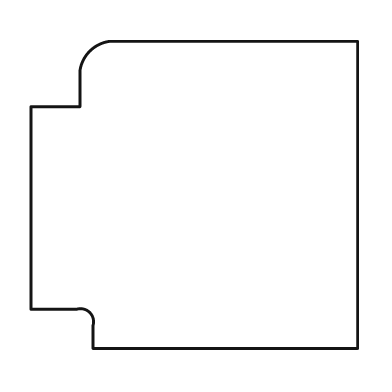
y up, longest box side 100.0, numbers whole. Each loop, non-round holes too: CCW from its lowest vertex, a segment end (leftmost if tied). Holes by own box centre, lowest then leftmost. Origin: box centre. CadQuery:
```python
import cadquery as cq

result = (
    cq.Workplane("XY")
    .moveTo(-31.0, -47.0)
    .lineTo(50.0, -47.0)
    .lineTo(50.0, 47.0)
    .lineTo(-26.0, 47.0)
    .threePointArc((-32.0, 44.0), (-35.0, 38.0))
    .lineTo(-35.0, 27.0)
    .lineTo(-50.0, 27.0)
    .lineTo(-50.0, -35.0)
    .lineTo(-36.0, -35.0)
    .threePointArc((-32.0, -36.0), (-31.0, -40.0))
    .close()
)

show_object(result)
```